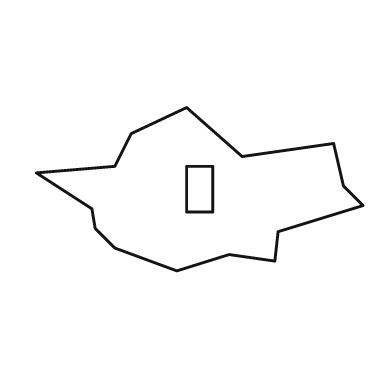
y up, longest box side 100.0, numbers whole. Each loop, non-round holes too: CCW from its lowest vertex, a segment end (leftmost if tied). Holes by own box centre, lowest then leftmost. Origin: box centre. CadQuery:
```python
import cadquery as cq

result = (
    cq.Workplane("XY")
    .moveTo(-7.0, -25.0)
    .lineTo(9.0, -20.0)
    .lineTo(23.0, -22.0)
    .lineTo(24.0, -13.0)
    .lineTo(50.0, -5.0)
    .lineTo(44.0, 1.0)
    .lineTo(41.0, 14.0)
    .lineTo(13.0, 10.0)
    .lineTo(-4.0, 25.0)
    .lineTo(-21.0, 17.0)
    .lineTo(-26.0, 7.0)
    .lineTo(-50.0, 5.0)
    .lineTo(-33.0, -6.0)
    .lineTo(-32.0, -12.0)
    .lineTo(-26.0, -18.0)
    .close()
    .moveTo(-4.0, -7.0)
    .lineTo(4.0, -7.0)
    .lineTo(4.0, 7.0)
    .lineTo(-4.0, 7.0)
    .close()
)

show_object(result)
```